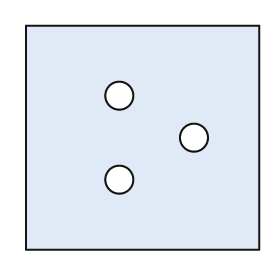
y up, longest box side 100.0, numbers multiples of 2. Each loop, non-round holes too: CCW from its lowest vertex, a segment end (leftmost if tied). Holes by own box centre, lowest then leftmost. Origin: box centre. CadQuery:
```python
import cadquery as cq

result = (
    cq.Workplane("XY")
    .moveTo(-50.0, -48.0)
    .lineTo(50.0, -48.0)
    .lineTo(50.0, 48.0)
    .lineTo(-50.0, 48.0)
    .close()
    .moveTo(-10.0, -18.0)
    .circle(6.0)
    .moveTo(22.0, 0.0)
    .circle(6.0)
    .moveTo(-10.0, 18.0)
    .circle(6.0)
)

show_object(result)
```